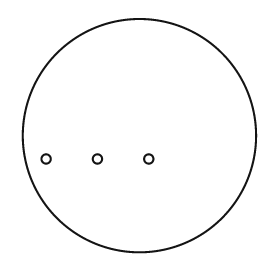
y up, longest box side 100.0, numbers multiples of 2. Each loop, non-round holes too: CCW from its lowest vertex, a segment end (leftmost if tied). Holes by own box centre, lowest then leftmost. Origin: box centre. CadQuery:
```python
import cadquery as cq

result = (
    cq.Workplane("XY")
    .moveTo(0.0, 0.0)
    .circle(50.0)
    .moveTo(-40.0, -10.0)
    .circle(2.0)
    .moveTo(-18.0, -10.0)
    .circle(2.0)
    .moveTo(4.0, -10.0)
    .circle(2.0)
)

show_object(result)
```